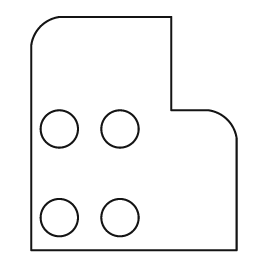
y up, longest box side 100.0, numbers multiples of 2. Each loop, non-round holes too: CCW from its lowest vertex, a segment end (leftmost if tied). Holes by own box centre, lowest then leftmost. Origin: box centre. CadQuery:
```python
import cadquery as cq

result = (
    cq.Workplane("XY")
    .moveTo(-44.0, -50.0)
    .lineTo(44.0, -50.0)
    .lineTo(44.0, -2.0)
    .threePointArc((40.0, 6.0), (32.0, 10.0))
    .lineTo(16.0, 10.0)
    .lineTo(16.0, 50.0)
    .lineTo(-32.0, 50.0)
    .threePointArc((-40.0, 46.0), (-44.0, 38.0))
    .close()
    .moveTo(-32.0, -36.0)
    .circle(8.0)
    .moveTo(-6.0, -36.0)
    .circle(8.0)
    .moveTo(-32.0, 2.0)
    .circle(8.0)
    .moveTo(-6.0, 2.0)
    .circle(8.0)
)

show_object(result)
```